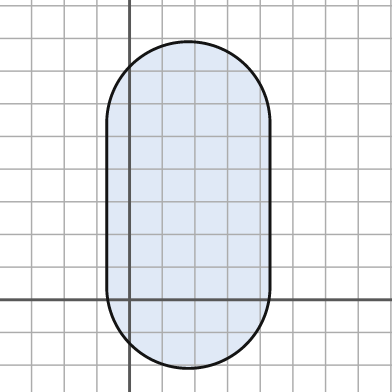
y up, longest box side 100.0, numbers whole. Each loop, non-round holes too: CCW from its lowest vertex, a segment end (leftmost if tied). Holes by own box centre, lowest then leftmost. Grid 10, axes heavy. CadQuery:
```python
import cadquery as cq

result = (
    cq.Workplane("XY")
    .moveTo(-7.0, 4.0)
    .threePointArc((18.0, -21.0), (43.0, 4.0))
    .lineTo(43.0, 54.0)
    .threePointArc((18.0, 79.0), (-7.0, 54.0))
    .close()
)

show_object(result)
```